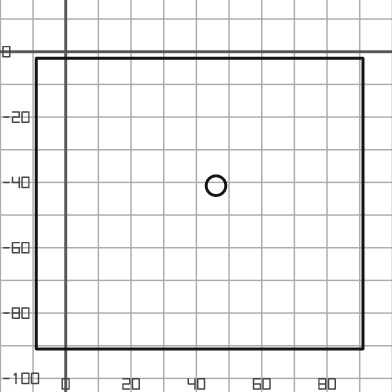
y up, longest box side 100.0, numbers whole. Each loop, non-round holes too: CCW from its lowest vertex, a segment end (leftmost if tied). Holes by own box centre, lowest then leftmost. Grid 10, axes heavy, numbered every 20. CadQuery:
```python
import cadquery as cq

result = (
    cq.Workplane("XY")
    .moveTo(-9.0, -91.0)
    .lineTo(91.0, -91.0)
    .lineTo(91.0, -2.0)
    .lineTo(-9.0, -2.0)
    .close()
    .moveTo(46.0, -41.0)
    .circle(3.0)
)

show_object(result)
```